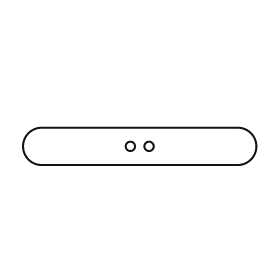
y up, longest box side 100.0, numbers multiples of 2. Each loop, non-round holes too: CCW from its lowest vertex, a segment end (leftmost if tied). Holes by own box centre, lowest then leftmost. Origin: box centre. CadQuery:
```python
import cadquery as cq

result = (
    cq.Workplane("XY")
    .moveTo(-42.0, -8.0)
    .lineTo(42.0, -8.0)
    .threePointArc((50.0, 0.0), (42.0, 8.0))
    .lineTo(-42.0, 8.0)
    .threePointArc((-50.0, 0.0), (-42.0, -8.0))
    .close()
    .moveTo(-4.0, 0.0)
    .circle(2.0)
    .moveTo(4.0, 0.0)
    .circle(2.0)
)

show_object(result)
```